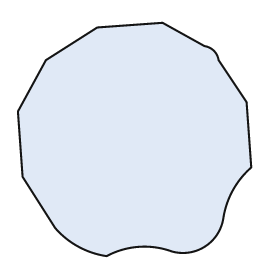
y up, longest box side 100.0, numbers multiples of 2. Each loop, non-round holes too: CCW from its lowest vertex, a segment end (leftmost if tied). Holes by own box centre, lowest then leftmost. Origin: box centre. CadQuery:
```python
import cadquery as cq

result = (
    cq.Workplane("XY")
    .moveTo(-12.0, -50.0)
    .threePointArc((2.0, -46.0), (16.0, -48.0))
    .threePointArc((30.0, -46.0), (38.0, -34.0))
    .threePointArc((42.0, -22.0), (50.0, -12.0))
    .lineTo(48.0, 16.0)
    .lineTo(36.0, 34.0)
    .threePointArc((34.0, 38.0), (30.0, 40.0))
    .lineTo(12.0, 50.0)
    .lineTo(-16.0, 48.0)
    .lineTo(-38.0, 34.0)
    .lineTo(-50.0, 12.0)
    .lineTo(-48.0, -16.0)
    .lineTo(-34.0, -38.0)
    .threePointArc((-24.0, -46.0), (-12.0, -50.0))
    .close()
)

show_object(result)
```